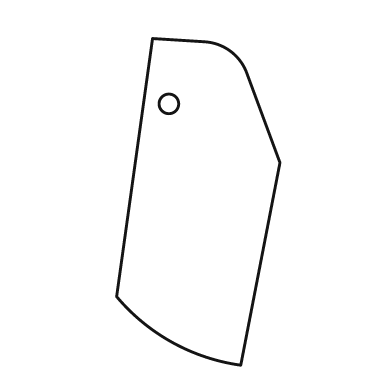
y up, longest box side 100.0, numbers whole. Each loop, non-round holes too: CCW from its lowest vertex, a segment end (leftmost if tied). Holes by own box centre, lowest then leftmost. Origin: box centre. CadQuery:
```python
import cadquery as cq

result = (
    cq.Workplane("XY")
    .moveTo(13.0, -50.0)
    .lineTo(25.0, 12.0)
    .lineTo(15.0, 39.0)
    .threePointArc((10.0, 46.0), (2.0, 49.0))
    .lineTo(-14.0, 50.0)
    .lineTo(-25.0, -29.0)
    .threePointArc((-8.0, -43.0), (13.0, -50.0))
    .close()
    .moveTo(-9.0, 30.0)
    .circle(3.0)
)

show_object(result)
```